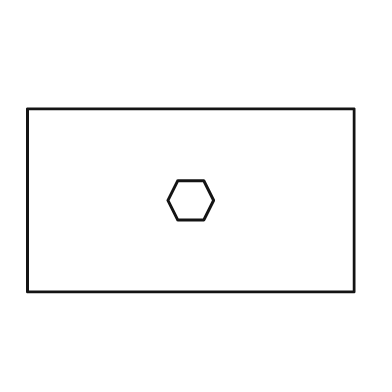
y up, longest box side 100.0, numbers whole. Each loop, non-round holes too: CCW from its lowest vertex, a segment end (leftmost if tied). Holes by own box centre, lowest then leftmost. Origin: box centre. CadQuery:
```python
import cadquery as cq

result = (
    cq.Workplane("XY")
    .moveTo(-50.0, -28.0)
    .lineTo(50.0, -28.0)
    .lineTo(50.0, 28.0)
    .lineTo(-50.0, 28.0)
    .close()
    .moveTo(-4.0, -6.0)
    .lineTo(4.0, -6.0)
    .lineTo(7.0, 0.0)
    .lineTo(4.0, 6.0)
    .lineTo(-4.0, 6.0)
    .lineTo(-7.0, 0.0)
    .close()
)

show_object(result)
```